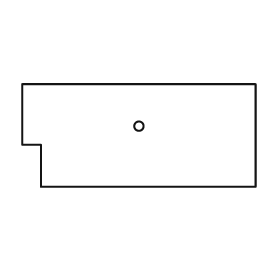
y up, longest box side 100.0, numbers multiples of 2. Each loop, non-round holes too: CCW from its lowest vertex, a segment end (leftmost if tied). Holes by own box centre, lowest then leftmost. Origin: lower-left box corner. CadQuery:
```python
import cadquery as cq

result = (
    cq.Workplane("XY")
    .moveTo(8.0, 0.0)
    .lineTo(100.0, 0.0)
    .lineTo(100.0, 44.0)
    .lineTo(0.0, 44.0)
    .lineTo(0.0, 18.0)
    .lineTo(8.0, 18.0)
    .close()
    .moveTo(50.0, 26.0)
    .circle(2.0)
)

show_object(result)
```